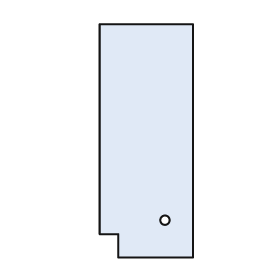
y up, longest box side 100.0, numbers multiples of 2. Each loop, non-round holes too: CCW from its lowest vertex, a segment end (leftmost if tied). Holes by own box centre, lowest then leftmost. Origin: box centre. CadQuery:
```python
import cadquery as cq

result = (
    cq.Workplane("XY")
    .moveTo(-12.0, -50.0)
    .lineTo(20.0, -50.0)
    .lineTo(20.0, 50.0)
    .lineTo(-20.0, 50.0)
    .lineTo(-20.0, -40.0)
    .lineTo(-12.0, -40.0)
    .close()
    .moveTo(8.0, -34.0)
    .circle(2.0)
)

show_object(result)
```